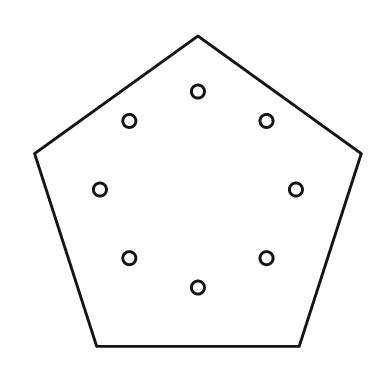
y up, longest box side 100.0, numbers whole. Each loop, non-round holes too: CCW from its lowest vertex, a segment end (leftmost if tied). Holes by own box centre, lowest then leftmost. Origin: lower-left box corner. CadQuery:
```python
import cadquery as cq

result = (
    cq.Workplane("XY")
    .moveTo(19.0, 0.0)
    .lineTo(81.0, 0.0)
    .lineTo(100.0, 59.0)
    .lineTo(50.0, 95.0)
    .lineTo(0.0, 59.0)
    .close()
    .moveTo(50.0, 18.0)
    .circle(2.0)
    .moveTo(29.0, 27.0)
    .circle(2.0)
    .moveTo(71.0, 27.0)
    .circle(2.0)
    .moveTo(20.0, 48.0)
    .circle(2.0)
    .moveTo(80.0, 48.0)
    .circle(2.0)
    .moveTo(29.0, 69.0)
    .circle(2.0)
    .moveTo(71.0, 69.0)
    .circle(2.0)
    .moveTo(50.0, 78.0)
    .circle(2.0)
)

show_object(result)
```